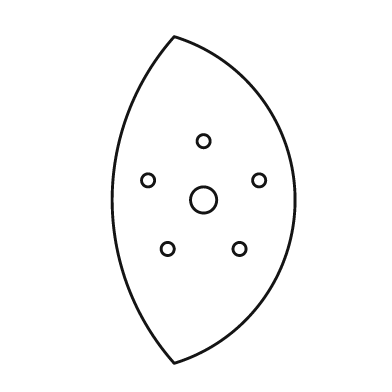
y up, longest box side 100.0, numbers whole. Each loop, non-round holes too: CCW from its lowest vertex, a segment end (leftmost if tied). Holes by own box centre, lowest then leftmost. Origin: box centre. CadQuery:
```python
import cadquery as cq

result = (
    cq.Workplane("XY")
    .moveTo(-9.0, -50.0)
    .threePointArc((28.0, 0.0), (-9.0, 50.0))
    .threePointArc((-28.0, 0.0), (-9.0, -50.0))
    .close()
    .moveTo(-11.0, -15.0)
    .circle(2.0)
    .moveTo(11.0, -15.0)
    .circle(2.0)
    .moveTo(0.0, 0.0)
    .circle(4.0)
    .moveTo(-17.0, 6.0)
    .circle(2.0)
    .moveTo(17.0, 6.0)
    .circle(2.0)
    .moveTo(0.0, 18.0)
    .circle(2.0)
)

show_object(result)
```